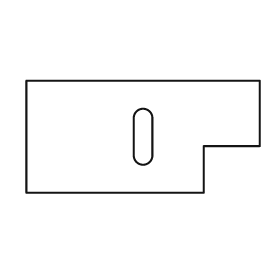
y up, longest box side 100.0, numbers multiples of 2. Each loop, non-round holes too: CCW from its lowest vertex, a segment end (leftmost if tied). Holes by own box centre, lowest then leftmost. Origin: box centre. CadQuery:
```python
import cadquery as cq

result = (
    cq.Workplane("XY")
    .moveTo(-50.0, -24.0)
    .lineTo(26.0, -24.0)
    .lineTo(26.0, -4.0)
    .lineTo(50.0, -4.0)
    .lineTo(50.0, 24.0)
    .lineTo(-50.0, 24.0)
    .close()
    .moveTo(-4.0, -8.0)
    .threePointArc((0.0, -12.0), (4.0, -8.0))
    .lineTo(4.0, 8.0)
    .threePointArc((0.0, 12.0), (-4.0, 8.0))
    .close()
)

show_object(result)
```